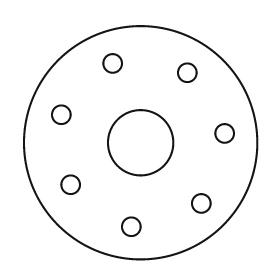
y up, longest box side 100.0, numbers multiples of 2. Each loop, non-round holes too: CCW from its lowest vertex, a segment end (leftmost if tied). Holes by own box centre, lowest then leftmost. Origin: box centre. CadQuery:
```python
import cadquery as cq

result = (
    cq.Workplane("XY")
    .moveTo(0.0, 0.0)
    .circle(50.0)
    .moveTo(-4.0, -36.0)
    .circle(4.0)
    .moveTo(26.0, -26.0)
    .circle(4.0)
    .moveTo(-30.0, -18.0)
    .circle(4.0)
    .moveTo(0.0, 0.0)
    .circle(14.0)
    .moveTo(36.0, 4.0)
    .circle(4.0)
    .moveTo(-34.0, 12.0)
    .circle(4.0)
    .moveTo(20.0, 30.0)
    .circle(4.0)
    .moveTo(-12.0, 34.0)
    .circle(4.0)
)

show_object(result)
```